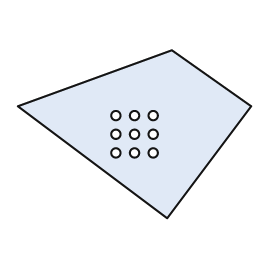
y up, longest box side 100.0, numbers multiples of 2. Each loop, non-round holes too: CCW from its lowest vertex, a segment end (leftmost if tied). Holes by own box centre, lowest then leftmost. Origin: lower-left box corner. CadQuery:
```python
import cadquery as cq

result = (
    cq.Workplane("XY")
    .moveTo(64.0, 0.0)
    .lineTo(100.0, 48.0)
    .lineTo(66.0, 72.0)
    .lineTo(0.0, 48.0)
    .close()
    .moveTo(42.0, 28.0)
    .circle(2.0)
    .moveTo(50.0, 28.0)
    .circle(2.0)
    .moveTo(58.0, 28.0)
    .circle(2.0)
    .moveTo(42.0, 36.0)
    .circle(2.0)
    .moveTo(50.0, 36.0)
    .circle(2.0)
    .moveTo(58.0, 36.0)
    .circle(2.0)
    .moveTo(42.0, 44.0)
    .circle(2.0)
    .moveTo(50.0, 44.0)
    .circle(2.0)
    .moveTo(58.0, 44.0)
    .circle(2.0)
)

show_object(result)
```